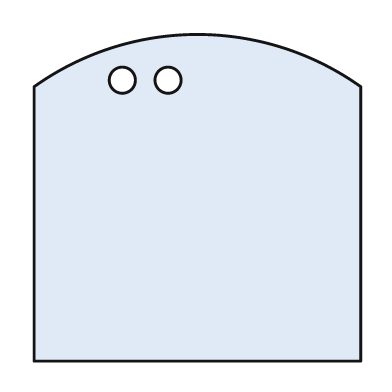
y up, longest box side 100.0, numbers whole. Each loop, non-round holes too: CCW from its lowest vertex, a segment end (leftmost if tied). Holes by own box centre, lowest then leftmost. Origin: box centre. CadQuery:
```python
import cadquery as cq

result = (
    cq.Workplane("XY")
    .moveTo(-50.0, -50.0)
    .lineTo(50.0, -50.0)
    .lineTo(50.0, 34.0)
    .threePointArc((0.0, 50.0), (-50.0, 34.0))
    .close()
    .moveTo(-23.0, 36.0)
    .circle(4.0)
    .moveTo(-9.0, 36.0)
    .circle(4.0)
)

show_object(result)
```